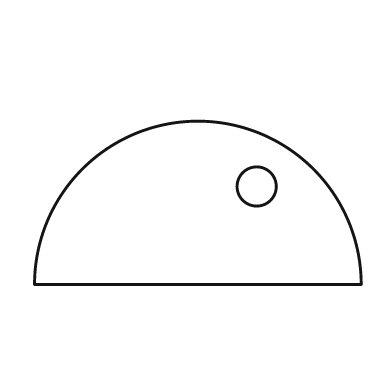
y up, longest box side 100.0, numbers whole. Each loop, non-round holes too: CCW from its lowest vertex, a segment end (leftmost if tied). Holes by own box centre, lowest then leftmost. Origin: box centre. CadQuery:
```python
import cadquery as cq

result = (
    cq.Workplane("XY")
    .moveTo(-50.0, -25.0)
    .lineTo(50.0, -25.0)
    .threePointArc((0.0, 25.0), (-50.0, -25.0))
    .close()
    .moveTo(18.0, 5.0)
    .circle(6.0)
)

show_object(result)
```